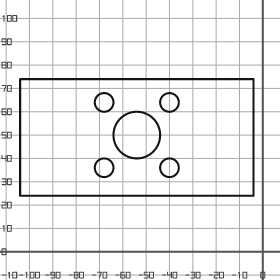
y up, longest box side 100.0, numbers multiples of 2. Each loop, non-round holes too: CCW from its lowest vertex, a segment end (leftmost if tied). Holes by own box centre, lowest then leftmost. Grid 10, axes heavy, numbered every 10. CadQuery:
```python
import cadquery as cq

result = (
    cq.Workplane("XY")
    .moveTo(-104.0, 24.0)
    .lineTo(-4.0, 24.0)
    .lineTo(-4.0, 74.0)
    .lineTo(-104.0, 74.0)
    .close()
    .moveTo(-68.0, 36.0)
    .circle(4.0)
    .moveTo(-40.0, 36.0)
    .circle(4.0)
    .moveTo(-54.0, 50.0)
    .circle(10.0)
    .moveTo(-68.0, 64.0)
    .circle(4.0)
    .moveTo(-40.0, 64.0)
    .circle(4.0)
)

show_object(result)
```